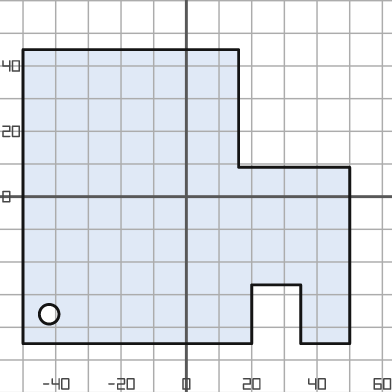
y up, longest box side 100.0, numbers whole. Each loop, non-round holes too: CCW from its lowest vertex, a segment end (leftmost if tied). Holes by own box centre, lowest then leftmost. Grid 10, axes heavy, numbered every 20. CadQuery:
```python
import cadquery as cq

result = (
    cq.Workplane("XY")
    .moveTo(-50.0, -45.0)
    .lineTo(20.0, -45.0)
    .lineTo(20.0, -27.0)
    .lineTo(35.0, -27.0)
    .lineTo(35.0, -45.0)
    .lineTo(50.0, -45.0)
    .lineTo(50.0, 9.0)
    .lineTo(16.0, 9.0)
    .lineTo(16.0, 45.0)
    .lineTo(-50.0, 45.0)
    .close()
    .moveTo(-42.0, -36.0)
    .circle(3.0)
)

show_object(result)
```